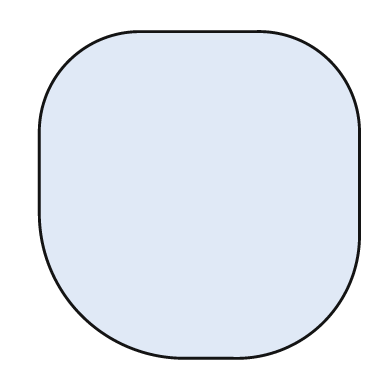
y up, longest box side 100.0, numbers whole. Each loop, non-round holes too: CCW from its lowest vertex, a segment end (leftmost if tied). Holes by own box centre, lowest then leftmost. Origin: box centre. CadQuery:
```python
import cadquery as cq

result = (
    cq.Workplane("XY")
    .moveTo(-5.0, -50.0)
    .lineTo(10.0, -50.0)
    .threePointArc((38.0, -39.0), (49.0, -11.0))
    .lineTo(49.0, 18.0)
    .threePointArc((40.0, 41.0), (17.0, 50.0))
    .lineTo(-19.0, 50.0)
    .threePointArc((-40.0, 41.0), (-49.0, 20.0))
    .lineTo(-49.0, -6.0)
    .threePointArc((-36.0, -37.0), (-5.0, -50.0))
    .close()
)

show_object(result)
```